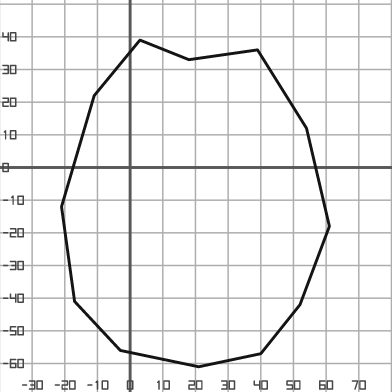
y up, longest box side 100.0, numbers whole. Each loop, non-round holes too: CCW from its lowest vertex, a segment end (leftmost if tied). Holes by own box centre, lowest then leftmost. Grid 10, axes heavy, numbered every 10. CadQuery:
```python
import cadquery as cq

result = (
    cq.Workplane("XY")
    .moveTo(21.0, -61.0)
    .lineTo(40.0, -57.0)
    .lineTo(52.0, -42.0)
    .lineTo(61.0, -18.0)
    .lineTo(54.0, 12.0)
    .lineTo(39.0, 36.0)
    .lineTo(18.0, 33.0)
    .lineTo(3.0, 39.0)
    .lineTo(-11.0, 22.0)
    .lineTo(-21.0, -12.0)
    .lineTo(-17.0, -41.0)
    .lineTo(-3.0, -56.0)
    .close()
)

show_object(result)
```